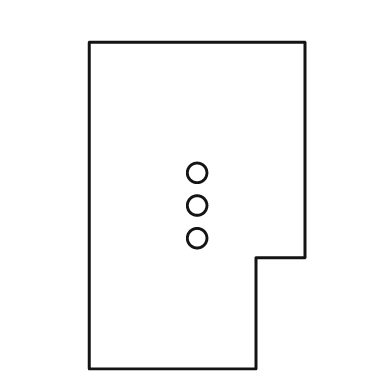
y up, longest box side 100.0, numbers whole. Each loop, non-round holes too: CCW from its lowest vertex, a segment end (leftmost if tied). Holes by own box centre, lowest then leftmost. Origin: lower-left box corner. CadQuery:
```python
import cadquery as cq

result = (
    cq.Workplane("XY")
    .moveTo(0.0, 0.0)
    .lineTo(51.0, 0.0)
    .lineTo(51.0, 34.0)
    .lineTo(66.0, 34.0)
    .lineTo(66.0, 100.0)
    .lineTo(0.0, 100.0)
    .close()
    .moveTo(33.0, 40.0)
    .circle(3.0)
    .moveTo(33.0, 50.0)
    .circle(3.0)
    .moveTo(33.0, 60.0)
    .circle(3.0)
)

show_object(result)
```